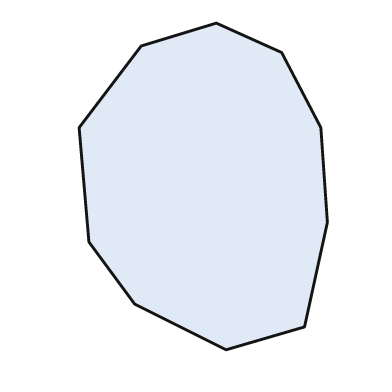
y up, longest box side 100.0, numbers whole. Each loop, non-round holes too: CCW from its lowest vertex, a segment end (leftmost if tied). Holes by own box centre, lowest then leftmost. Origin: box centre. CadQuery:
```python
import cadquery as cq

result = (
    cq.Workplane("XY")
    .moveTo(7.0, -50.0)
    .lineTo(31.0, -43.0)
    .lineTo(38.0, -11.0)
    .lineTo(36.0, 18.0)
    .lineTo(24.0, 41.0)
    .lineTo(4.0, 50.0)
    .lineTo(-19.0, 43.0)
    .lineTo(-38.0, 18.0)
    .lineTo(-35.0, -17.0)
    .lineTo(-21.0, -36.0)
    .close()
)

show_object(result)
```